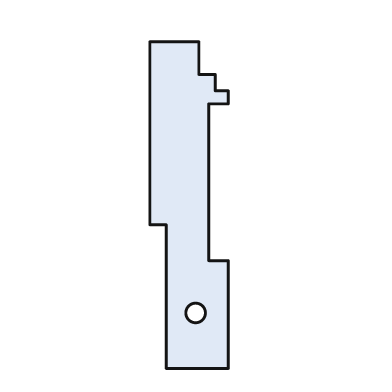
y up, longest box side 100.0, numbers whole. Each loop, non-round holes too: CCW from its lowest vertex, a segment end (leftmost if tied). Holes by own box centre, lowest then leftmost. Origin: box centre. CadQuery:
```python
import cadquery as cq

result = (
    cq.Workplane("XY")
    .moveTo(-7.0, -50.0)
    .lineTo(12.0, -50.0)
    .lineTo(12.0, -17.0)
    .lineTo(6.0, -17.0)
    .lineTo(6.0, 31.0)
    .lineTo(12.0, 31.0)
    .lineTo(12.0, 35.0)
    .lineTo(8.0, 35.0)
    .lineTo(8.0, 40.0)
    .lineTo(3.0, 40.0)
    .lineTo(3.0, 50.0)
    .lineTo(-12.0, 50.0)
    .lineTo(-12.0, -6.0)
    .lineTo(-7.0, -6.0)
    .close()
    .moveTo(2.0, -33.0)
    .circle(3.0)
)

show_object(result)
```